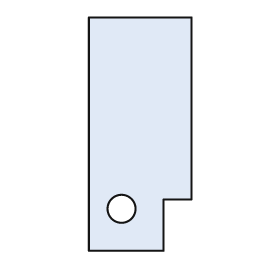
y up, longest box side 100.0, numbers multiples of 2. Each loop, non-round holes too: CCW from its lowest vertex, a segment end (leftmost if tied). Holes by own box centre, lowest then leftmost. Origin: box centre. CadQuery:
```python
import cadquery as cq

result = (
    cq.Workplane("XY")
    .moveTo(-22.0, -50.0)
    .lineTo(10.0, -50.0)
    .lineTo(10.0, -28.0)
    .lineTo(22.0, -28.0)
    .lineTo(22.0, 50.0)
    .lineTo(-22.0, 50.0)
    .close()
    .moveTo(-8.0, -32.0)
    .circle(6.0)
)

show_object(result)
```